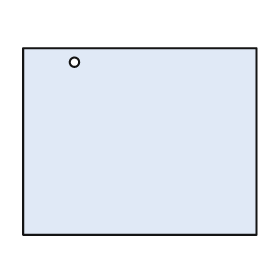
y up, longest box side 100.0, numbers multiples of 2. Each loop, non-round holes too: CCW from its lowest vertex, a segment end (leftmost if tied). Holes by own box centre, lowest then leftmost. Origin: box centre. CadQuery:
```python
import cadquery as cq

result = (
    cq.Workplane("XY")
    .moveTo(-50.0, -40.0)
    .lineTo(50.0, -40.0)
    .lineTo(50.0, 40.0)
    .lineTo(-50.0, 40.0)
    .close()
    .moveTo(-28.0, 34.0)
    .circle(2.0)
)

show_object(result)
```